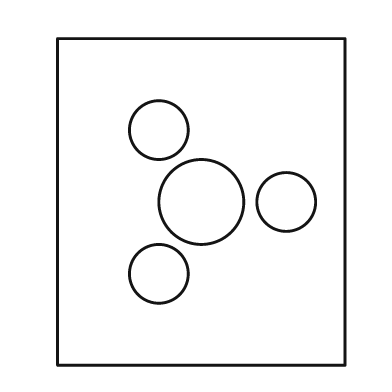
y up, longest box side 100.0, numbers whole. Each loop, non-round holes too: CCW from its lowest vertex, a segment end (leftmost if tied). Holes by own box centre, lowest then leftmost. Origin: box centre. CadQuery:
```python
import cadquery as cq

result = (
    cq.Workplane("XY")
    .moveTo(-44.0, -50.0)
    .lineTo(44.0, -50.0)
    .lineTo(44.0, 50.0)
    .lineTo(-44.0, 50.0)
    .close()
    .moveTo(-13.0, -22.0)
    .circle(9.0)
    .moveTo(0.0, 0.0)
    .circle(13.0)
    .moveTo(26.0, 0.0)
    .circle(9.0)
    .moveTo(-13.0, 22.0)
    .circle(9.0)
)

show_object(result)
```